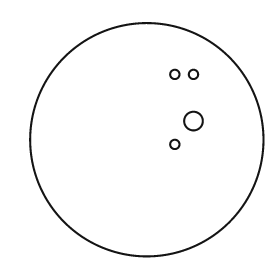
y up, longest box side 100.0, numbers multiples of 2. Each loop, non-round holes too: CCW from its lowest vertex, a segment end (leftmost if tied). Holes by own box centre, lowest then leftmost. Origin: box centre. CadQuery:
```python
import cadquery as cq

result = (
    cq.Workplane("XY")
    .moveTo(0.0, 0.0)
    .circle(50.0)
    .moveTo(12.0, -2.0)
    .circle(2.0)
    .moveTo(20.0, 8.0)
    .circle(4.0)
    .moveTo(12.0, 28.0)
    .circle(2.0)
    .moveTo(20.0, 28.0)
    .circle(2.0)
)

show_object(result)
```